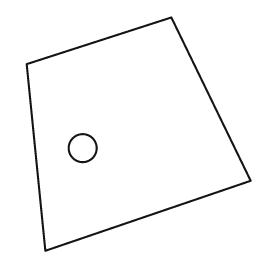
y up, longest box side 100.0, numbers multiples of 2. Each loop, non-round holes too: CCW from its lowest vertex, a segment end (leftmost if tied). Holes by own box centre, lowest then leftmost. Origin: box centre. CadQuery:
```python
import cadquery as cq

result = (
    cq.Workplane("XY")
    .moveTo(-40.0, -50.0)
    .lineTo(48.0, -20.0)
    .lineTo(14.0, 50.0)
    .lineTo(-48.0, 30.0)
    .close()
    .moveTo(-24.0, -6.0)
    .circle(6.0)
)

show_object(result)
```